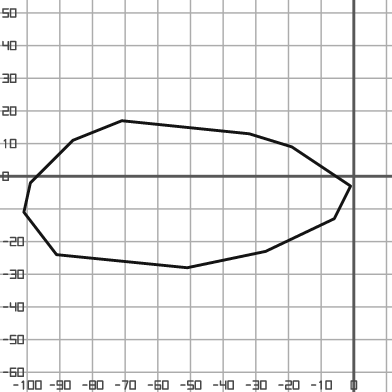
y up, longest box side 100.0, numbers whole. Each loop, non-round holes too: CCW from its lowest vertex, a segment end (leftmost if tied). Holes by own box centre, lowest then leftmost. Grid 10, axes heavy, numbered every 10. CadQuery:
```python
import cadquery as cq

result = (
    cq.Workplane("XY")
    .moveTo(-51.0, -28.0)
    .lineTo(-27.0, -23.0)
    .lineTo(-6.0, -13.0)
    .lineTo(-1.0, -3.0)
    .lineTo(-19.0, 9.0)
    .lineTo(-32.0, 13.0)
    .lineTo(-71.0, 17.0)
    .lineTo(-86.0, 11.0)
    .lineTo(-99.0, -2.0)
    .lineTo(-101.0, -11.0)
    .lineTo(-91.0, -24.0)
    .close()
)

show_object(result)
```